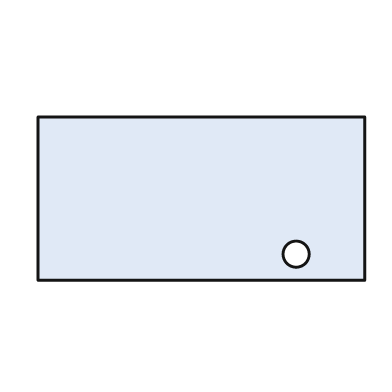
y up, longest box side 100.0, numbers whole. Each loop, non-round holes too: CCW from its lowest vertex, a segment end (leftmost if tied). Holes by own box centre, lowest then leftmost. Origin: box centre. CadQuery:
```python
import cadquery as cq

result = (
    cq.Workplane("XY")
    .moveTo(-50.0, -25.0)
    .lineTo(50.0, -25.0)
    .lineTo(50.0, 25.0)
    .lineTo(-50.0, 25.0)
    .close()
    .moveTo(29.0, -17.0)
    .circle(4.0)
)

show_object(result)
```